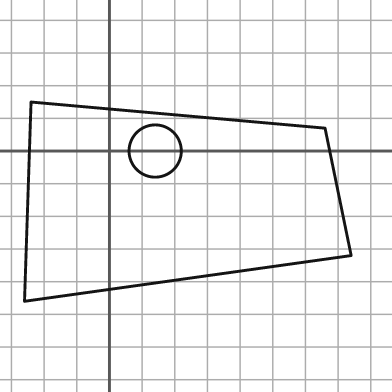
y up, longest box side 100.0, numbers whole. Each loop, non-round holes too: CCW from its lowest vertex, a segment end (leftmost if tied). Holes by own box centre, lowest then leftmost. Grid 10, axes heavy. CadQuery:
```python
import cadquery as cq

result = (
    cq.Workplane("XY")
    .moveTo(-26.0, -46.0)
    .lineTo(74.0, -32.0)
    .lineTo(66.0, 7.0)
    .lineTo(-24.0, 15.0)
    .close()
    .moveTo(14.0, 0.0)
    .circle(8.0)
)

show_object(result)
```